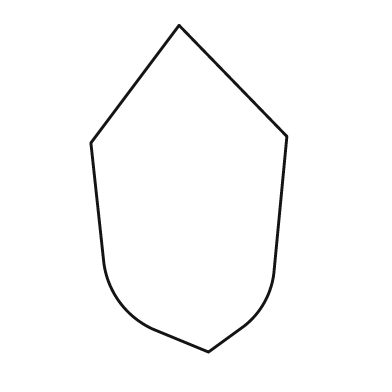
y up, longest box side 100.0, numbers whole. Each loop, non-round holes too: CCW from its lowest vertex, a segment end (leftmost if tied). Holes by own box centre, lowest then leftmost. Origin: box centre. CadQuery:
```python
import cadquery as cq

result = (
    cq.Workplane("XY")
    .moveTo(6.0, -50.0)
    .lineTo(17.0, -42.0)
    .threePointArc((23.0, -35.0), (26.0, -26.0))
    .lineTo(30.0, 16.0)
    .lineTo(-3.0, 50.0)
    .lineTo(-30.0, 14.0)
    .lineTo(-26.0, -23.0)
    .threePointArc((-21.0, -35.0), (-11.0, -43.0))
    .close()
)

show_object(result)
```